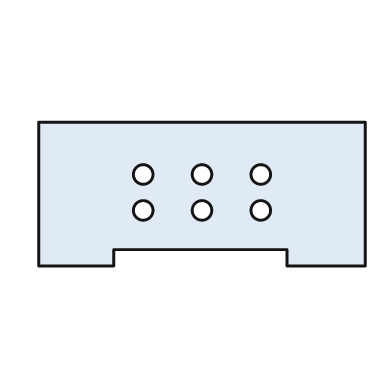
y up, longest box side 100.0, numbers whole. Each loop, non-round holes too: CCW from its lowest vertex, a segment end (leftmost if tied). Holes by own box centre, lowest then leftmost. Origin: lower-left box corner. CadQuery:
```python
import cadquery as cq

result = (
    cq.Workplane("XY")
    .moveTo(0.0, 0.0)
    .lineTo(23.0, 0.0)
    .lineTo(23.0, 5.0)
    .lineTo(76.0, 5.0)
    .lineTo(76.0, 0.0)
    .lineTo(100.0, 0.0)
    .lineTo(100.0, 44.0)
    .lineTo(0.0, 44.0)
    .close()
    .moveTo(32.0, 17.0)
    .circle(3.0)
    .moveTo(50.0, 17.0)
    .circle(3.0)
    .moveTo(68.0, 17.0)
    .circle(3.0)
    .moveTo(32.0, 28.0)
    .circle(3.0)
    .moveTo(50.0, 28.0)
    .circle(3.0)
    .moveTo(68.0, 28.0)
    .circle(3.0)
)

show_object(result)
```